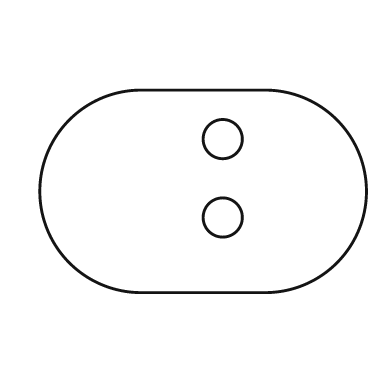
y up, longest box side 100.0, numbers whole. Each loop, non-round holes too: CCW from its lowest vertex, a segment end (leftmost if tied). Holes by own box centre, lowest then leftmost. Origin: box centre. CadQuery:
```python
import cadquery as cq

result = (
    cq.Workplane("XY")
    .moveTo(-19.0, -31.0)
    .lineTo(19.0, -31.0)
    .threePointArc((50.0, 0.0), (19.0, 31.0))
    .lineTo(-19.0, 31.0)
    .threePointArc((-50.0, 0.0), (-19.0, -31.0))
    .close()
    .moveTo(6.0, -8.0)
    .circle(6.0)
    .moveTo(6.0, 16.0)
    .circle(6.0)
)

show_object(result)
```